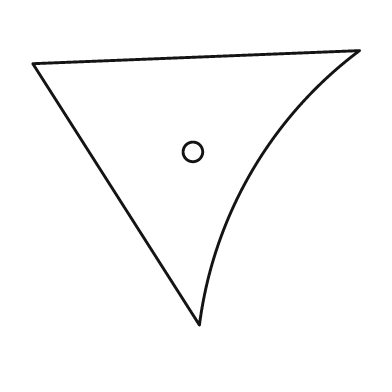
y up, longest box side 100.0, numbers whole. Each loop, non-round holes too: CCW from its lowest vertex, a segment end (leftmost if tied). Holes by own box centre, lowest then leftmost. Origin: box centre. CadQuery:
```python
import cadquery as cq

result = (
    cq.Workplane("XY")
    .moveTo(1.0, -42.0)
    .threePointArc((17.0, 5.0), (50.0, 42.0))
    .lineTo(-50.0, 38.0)
    .close()
    .moveTo(-1.0, 11.0)
    .circle(3.0)
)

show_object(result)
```